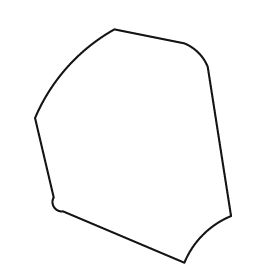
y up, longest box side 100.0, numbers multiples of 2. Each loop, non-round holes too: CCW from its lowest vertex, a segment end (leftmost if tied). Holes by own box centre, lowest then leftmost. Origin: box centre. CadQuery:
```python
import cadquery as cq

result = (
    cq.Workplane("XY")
    .moveTo(22.0, -50.0)
    .threePointArc((30.0, -38.0), (42.0, -30.0))
    .lineTo(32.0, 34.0)
    .threePointArc((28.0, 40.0), (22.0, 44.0))
    .lineTo(-8.0, 50.0)
    .threePointArc((-28.0, 34.0), (-42.0, 12.0))
    .lineTo(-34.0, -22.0)
    .threePointArc((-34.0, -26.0), (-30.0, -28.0))
    .close()
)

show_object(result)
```